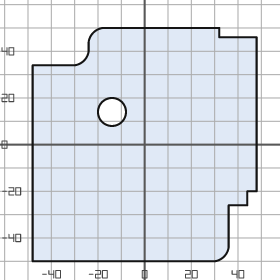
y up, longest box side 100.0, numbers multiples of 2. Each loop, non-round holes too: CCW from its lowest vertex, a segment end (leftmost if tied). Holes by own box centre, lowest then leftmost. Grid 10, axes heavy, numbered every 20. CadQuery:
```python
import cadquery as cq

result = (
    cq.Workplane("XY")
    .moveTo(-48.0, -50.0)
    .lineTo(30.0, -50.0)
    .threePointArc((34.0, -48.0), (36.0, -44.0))
    .lineTo(36.0, -26.0)
    .lineTo(44.0, -26.0)
    .lineTo(44.0, -20.0)
    .lineTo(48.0, -20.0)
    .lineTo(48.0, 46.0)
    .lineTo(32.0, 46.0)
    .lineTo(32.0, 50.0)
    .lineTo(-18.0, 50.0)
    .threePointArc((-22.0, 48.0), (-24.0, 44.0))
    .lineTo(-24.0, 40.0)
    .threePointArc((-26.0, 36.0), (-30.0, 34.0))
    .lineTo(-48.0, 34.0)
    .close()
    .moveTo(-14.0, 14.0)
    .circle(6.0)
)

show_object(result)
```